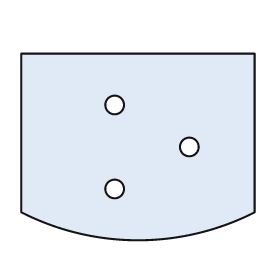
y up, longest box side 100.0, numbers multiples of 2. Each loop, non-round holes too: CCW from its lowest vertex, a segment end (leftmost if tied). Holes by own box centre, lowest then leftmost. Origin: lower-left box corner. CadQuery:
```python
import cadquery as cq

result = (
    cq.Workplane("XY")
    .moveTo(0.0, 12.0)
    .threePointArc((50.0, 0.0), (100.0, 12.0))
    .lineTo(100.0, 80.0)
    .lineTo(0.0, 80.0)
    .close()
    .moveTo(40.0, 22.0)
    .circle(4.0)
    .moveTo(72.0, 40.0)
    .circle(4.0)
    .moveTo(40.0, 58.0)
    .circle(4.0)
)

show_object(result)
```